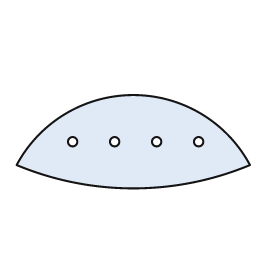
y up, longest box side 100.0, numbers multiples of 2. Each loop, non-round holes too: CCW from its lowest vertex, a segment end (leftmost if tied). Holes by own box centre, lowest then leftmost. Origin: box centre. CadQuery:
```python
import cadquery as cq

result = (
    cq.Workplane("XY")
    .moveTo(-50.0, -10.0)
    .threePointArc((0.0, -20.0), (50.0, -10.0))
    .threePointArc((0.0, 20.0), (-50.0, -10.0))
    .close()
    .moveTo(-26.0, 0.0)
    .circle(2.0)
    .moveTo(-8.0, 0.0)
    .circle(2.0)
    .moveTo(10.0, 0.0)
    .circle(2.0)
    .moveTo(28.0, 0.0)
    .circle(2.0)
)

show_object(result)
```